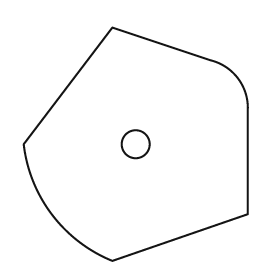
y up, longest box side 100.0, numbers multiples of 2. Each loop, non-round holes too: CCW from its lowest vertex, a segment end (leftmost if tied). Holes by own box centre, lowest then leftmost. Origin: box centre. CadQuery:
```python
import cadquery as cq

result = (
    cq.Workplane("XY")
    .moveTo(-10.0, -50.0)
    .lineTo(48.0, -30.0)
    .lineTo(48.0, 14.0)
    .threePointArc((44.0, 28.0), (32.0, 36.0))
    .lineTo(-10.0, 50.0)
    .lineTo(-48.0, 0.0)
    .threePointArc((-36.0, -30.0), (-10.0, -50.0))
    .close()
    .moveTo(0.0, 0.0)
    .circle(6.0)
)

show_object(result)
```